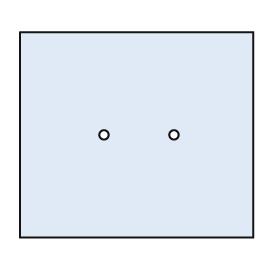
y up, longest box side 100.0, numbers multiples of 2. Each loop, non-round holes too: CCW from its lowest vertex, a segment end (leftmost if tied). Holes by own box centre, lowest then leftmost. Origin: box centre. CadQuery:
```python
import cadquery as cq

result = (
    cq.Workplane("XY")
    .moveTo(-50.0, -44.0)
    .lineTo(50.0, -44.0)
    .lineTo(50.0, 44.0)
    .lineTo(-50.0, 44.0)
    .close()
    .moveTo(-14.0, 0.0)
    .circle(2.0)
    .moveTo(16.0, 0.0)
    .circle(2.0)
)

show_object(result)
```